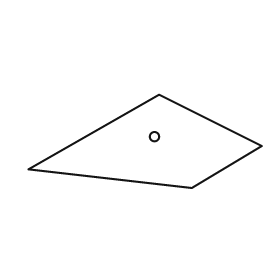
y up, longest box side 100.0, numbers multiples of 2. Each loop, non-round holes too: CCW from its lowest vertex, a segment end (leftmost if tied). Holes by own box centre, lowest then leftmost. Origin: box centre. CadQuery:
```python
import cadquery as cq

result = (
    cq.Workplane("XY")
    .moveTo(20.0, -20.0)
    .lineTo(50.0, -2.0)
    .lineTo(6.0, 20.0)
    .lineTo(-50.0, -12.0)
    .close()
    .moveTo(4.0, 2.0)
    .circle(2.0)
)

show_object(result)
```